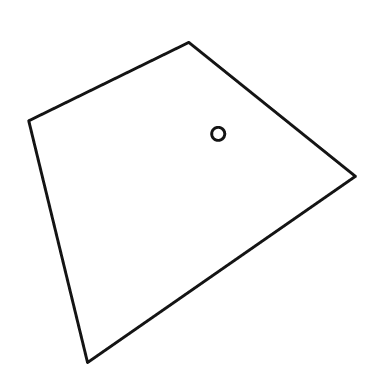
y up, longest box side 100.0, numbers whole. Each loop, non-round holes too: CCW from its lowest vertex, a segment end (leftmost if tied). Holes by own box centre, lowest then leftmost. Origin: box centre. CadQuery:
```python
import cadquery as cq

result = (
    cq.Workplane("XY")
    .moveTo(-32.0, -49.0)
    .lineTo(50.0, 8.0)
    .lineTo(-1.0, 49.0)
    .lineTo(-50.0, 25.0)
    .close()
    .moveTo(8.0, 21.0)
    .circle(2.0)
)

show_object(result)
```